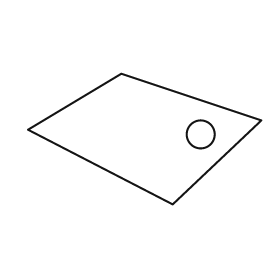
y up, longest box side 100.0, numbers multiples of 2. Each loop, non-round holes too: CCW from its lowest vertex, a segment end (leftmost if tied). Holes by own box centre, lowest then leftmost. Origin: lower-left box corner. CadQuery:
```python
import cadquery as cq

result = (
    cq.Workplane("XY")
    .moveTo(62.0, 0.0)
    .lineTo(100.0, 36.0)
    .lineTo(40.0, 56.0)
    .lineTo(0.0, 32.0)
    .close()
    .moveTo(74.0, 30.0)
    .circle(6.0)
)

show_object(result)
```